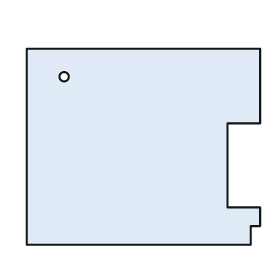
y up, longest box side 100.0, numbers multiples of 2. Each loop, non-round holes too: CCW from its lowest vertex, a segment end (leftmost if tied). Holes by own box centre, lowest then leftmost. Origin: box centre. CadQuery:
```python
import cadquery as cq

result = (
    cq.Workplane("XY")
    .moveTo(-50.0, -42.0)
    .lineTo(46.0, -42.0)
    .lineTo(46.0, -34.0)
    .lineTo(50.0, -34.0)
    .lineTo(50.0, -26.0)
    .lineTo(36.0, -26.0)
    .lineTo(36.0, 10.0)
    .lineTo(50.0, 10.0)
    .lineTo(50.0, 42.0)
    .lineTo(-50.0, 42.0)
    .close()
    .moveTo(-34.0, 30.0)
    .circle(2.0)
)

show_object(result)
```